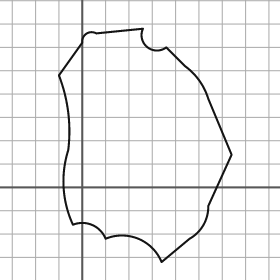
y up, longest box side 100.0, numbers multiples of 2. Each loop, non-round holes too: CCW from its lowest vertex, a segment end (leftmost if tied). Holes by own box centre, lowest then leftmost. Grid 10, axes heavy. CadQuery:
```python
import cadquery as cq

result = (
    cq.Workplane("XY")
    .moveTo(34.0, -32.0)
    .lineTo(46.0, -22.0)
    .threePointArc((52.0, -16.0), (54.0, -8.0))
    .lineTo(64.0, 14.0)
    .lineTo(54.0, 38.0)
    .threePointArc((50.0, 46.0), (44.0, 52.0))
    .lineTo(36.0, 60.0)
    .threePointArc((28.0, 60.0), (26.0, 68.0))
    .lineTo(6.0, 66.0)
    .threePointArc((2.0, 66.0), (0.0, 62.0))
    .lineTo(-10.0, 48.0)
    .threePointArc((-6.0, 32.0), (-6.0, 16.0))
    .threePointArc((-8.0, 0.0), (-4.0, -16.0))
    .threePointArc((4.0, -16.0), (10.0, -22.0))
    .threePointArc((24.0, -22.0), (34.0, -32.0))
    .close()
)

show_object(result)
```